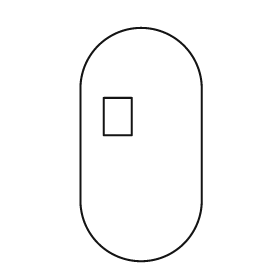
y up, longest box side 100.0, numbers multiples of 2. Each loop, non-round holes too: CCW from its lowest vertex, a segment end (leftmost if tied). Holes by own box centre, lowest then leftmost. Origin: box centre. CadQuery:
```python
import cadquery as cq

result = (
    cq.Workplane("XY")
    .moveTo(-26.0, -24.0)
    .threePointArc((0.0, -50.0), (26.0, -24.0))
    .lineTo(26.0, 24.0)
    .threePointArc((0.0, 50.0), (-26.0, 24.0))
    .close()
    .moveTo(-16.0, 4.0)
    .lineTo(-4.0, 4.0)
    .lineTo(-4.0, 20.0)
    .lineTo(-16.0, 20.0)
    .close()
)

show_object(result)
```